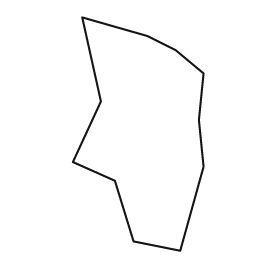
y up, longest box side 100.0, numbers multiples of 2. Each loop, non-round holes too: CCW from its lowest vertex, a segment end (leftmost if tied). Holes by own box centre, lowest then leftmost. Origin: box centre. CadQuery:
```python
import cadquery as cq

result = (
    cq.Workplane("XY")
    .moveTo(18.0, -50.0)
    .lineTo(28.0, -14.0)
    .lineTo(26.0, 6.0)
    .lineTo(28.0, 26.0)
    .lineTo(16.0, 36.0)
    .lineTo(4.0, 42.0)
    .lineTo(-24.0, 50.0)
    .lineTo(-16.0, 14.0)
    .lineTo(-28.0, -12.0)
    .lineTo(-10.0, -20.0)
    .lineTo(-2.0, -46.0)
    .close()
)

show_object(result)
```